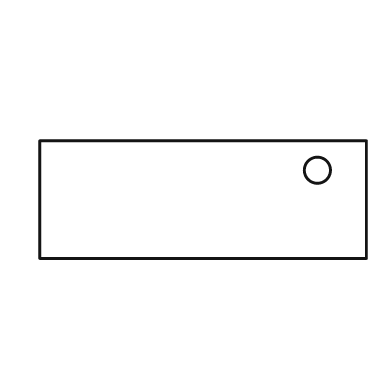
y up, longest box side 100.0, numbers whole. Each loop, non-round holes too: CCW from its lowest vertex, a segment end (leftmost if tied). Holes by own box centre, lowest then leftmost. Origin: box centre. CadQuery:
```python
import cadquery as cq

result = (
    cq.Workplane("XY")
    .moveTo(-50.0, -18.0)
    .lineTo(50.0, -18.0)
    .lineTo(50.0, 18.0)
    .lineTo(-50.0, 18.0)
    .close()
    .moveTo(35.0, 9.0)
    .circle(4.0)
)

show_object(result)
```